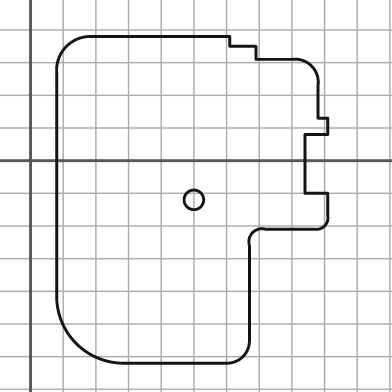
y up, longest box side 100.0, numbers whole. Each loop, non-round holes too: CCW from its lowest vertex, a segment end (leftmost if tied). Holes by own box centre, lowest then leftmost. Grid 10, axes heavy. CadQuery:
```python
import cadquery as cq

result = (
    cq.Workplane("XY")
    .moveTo(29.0, -62.0)
    .lineTo(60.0, -62.0)
    .threePointArc((65.0, -60.0), (67.0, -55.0))
    .lineTo(67.0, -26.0)
    .threePointArc((68.0, -22.0), (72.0, -21.0))
    .lineTo(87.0, -21.0)
    .threePointArc((90.0, -20.0), (91.0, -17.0))
    .lineTo(91.0, -10.0)
    .lineTo(84.0, -10.0)
    .lineTo(84.0, 8.0)
    .lineTo(91.0, 8.0)
    .lineTo(91.0, 13.0)
    .lineTo(88.0, 13.0)
    .lineTo(88.0, 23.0)
    .threePointArc((86.0, 29.0), (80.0, 31.0))
    .lineTo(69.0, 31.0)
    .lineTo(69.0, 35.0)
    .lineTo(61.0, 35.0)
    .lineTo(61.0, 38.0)
    .lineTo(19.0, 38.0)
    .threePointArc((11.0, 35.0), (8.0, 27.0))
    .lineTo(8.0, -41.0)
    .threePointArc((14.0, -56.0), (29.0, -62.0))
    .close()
    .moveTo(50.0, -12.0)
    .circle(3.0)
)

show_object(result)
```